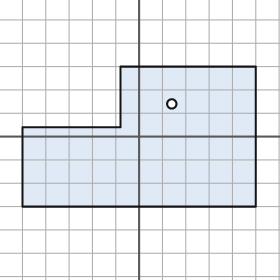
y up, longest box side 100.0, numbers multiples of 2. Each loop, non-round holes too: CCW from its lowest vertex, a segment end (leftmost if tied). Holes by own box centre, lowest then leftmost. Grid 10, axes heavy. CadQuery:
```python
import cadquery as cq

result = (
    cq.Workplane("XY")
    .moveTo(-50.0, -30.0)
    .lineTo(50.0, -30.0)
    .lineTo(50.0, 30.0)
    .lineTo(-8.0, 30.0)
    .lineTo(-8.0, 4.0)
    .lineTo(-50.0, 4.0)
    .close()
    .moveTo(14.0, 14.0)
    .circle(2.0)
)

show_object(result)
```